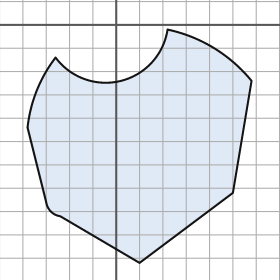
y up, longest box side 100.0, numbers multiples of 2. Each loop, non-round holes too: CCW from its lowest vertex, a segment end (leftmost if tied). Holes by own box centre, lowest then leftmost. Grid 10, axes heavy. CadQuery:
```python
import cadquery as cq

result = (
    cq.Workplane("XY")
    .moveTo(10.0, -102.0)
    .lineTo(50.0, -72.0)
    .lineTo(58.0, -24.0)
    .threePointArc((42.0, -10.0), (22.0, -2.0))
    .threePointArc((2.0, -24.0), (-26.0, -14.0))
    .threePointArc((-34.0, -28.0), (-38.0, -44.0))
    .lineTo(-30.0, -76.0)
    .threePointArc((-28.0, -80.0), (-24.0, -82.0))
    .close()
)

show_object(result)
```